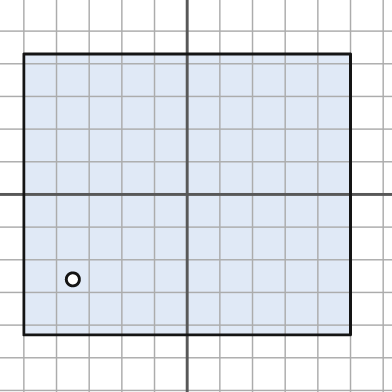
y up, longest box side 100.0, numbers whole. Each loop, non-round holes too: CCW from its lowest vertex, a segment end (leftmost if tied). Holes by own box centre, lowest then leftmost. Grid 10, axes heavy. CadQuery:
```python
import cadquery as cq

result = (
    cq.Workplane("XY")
    .moveTo(-50.0, -43.0)
    .lineTo(50.0, -43.0)
    .lineTo(50.0, 43.0)
    .lineTo(-50.0, 43.0)
    .close()
    .moveTo(-35.0, -26.0)
    .circle(2.0)
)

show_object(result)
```